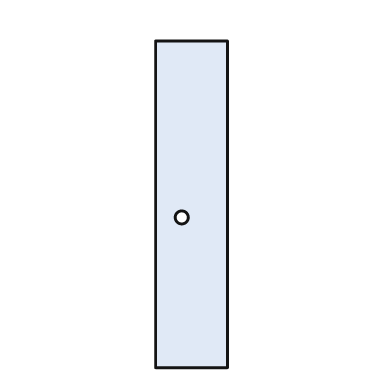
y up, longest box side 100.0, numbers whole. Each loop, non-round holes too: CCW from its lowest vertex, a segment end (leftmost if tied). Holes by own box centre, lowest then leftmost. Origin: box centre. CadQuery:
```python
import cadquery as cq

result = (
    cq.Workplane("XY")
    .moveTo(-11.0, -50.0)
    .lineTo(11.0, -50.0)
    .lineTo(11.0, 50.0)
    .lineTo(-11.0, 50.0)
    .close()
    .moveTo(-3.0, -4.0)
    .circle(2.0)
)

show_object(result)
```